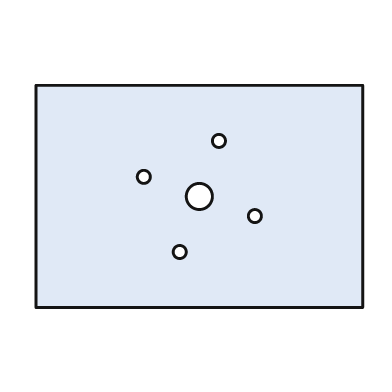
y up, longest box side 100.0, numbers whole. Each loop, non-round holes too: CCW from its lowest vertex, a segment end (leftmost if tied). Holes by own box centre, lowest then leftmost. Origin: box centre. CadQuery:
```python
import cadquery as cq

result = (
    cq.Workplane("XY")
    .moveTo(-50.0, -34.0)
    .lineTo(50.0, -34.0)
    .lineTo(50.0, 34.0)
    .lineTo(-50.0, 34.0)
    .close()
    .moveTo(-6.0, -17.0)
    .circle(2.0)
    .moveTo(17.0, -6.0)
    .circle(2.0)
    .moveTo(0.0, 0.0)
    .circle(4.0)
    .moveTo(-17.0, 6.0)
    .circle(2.0)
    .moveTo(6.0, 17.0)
    .circle(2.0)
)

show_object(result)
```